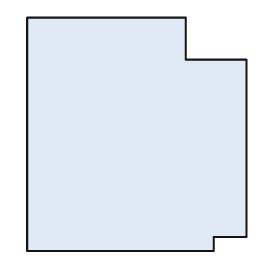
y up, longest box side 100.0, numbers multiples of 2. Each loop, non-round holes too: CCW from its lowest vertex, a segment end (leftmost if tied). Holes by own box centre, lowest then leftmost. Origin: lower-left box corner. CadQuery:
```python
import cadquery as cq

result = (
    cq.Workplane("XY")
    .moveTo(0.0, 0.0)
    .lineTo(80.0, 0.0)
    .lineTo(80.0, 6.0)
    .lineTo(94.0, 6.0)
    .lineTo(94.0, 82.0)
    .lineTo(68.0, 82.0)
    .lineTo(68.0, 100.0)
    .lineTo(0.0, 100.0)
    .close()
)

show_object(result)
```